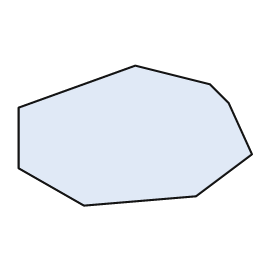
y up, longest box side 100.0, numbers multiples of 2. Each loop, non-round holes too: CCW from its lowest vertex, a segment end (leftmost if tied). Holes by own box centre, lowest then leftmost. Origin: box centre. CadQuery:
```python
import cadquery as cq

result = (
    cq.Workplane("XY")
    .moveTo(-22.0, -30.0)
    .lineTo(26.0, -26.0)
    .lineTo(50.0, -8.0)
    .lineTo(40.0, 14.0)
    .lineTo(32.0, 22.0)
    .lineTo(0.0, 30.0)
    .lineTo(-50.0, 12.0)
    .lineTo(-50.0, -14.0)
    .close()
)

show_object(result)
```